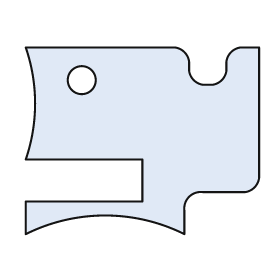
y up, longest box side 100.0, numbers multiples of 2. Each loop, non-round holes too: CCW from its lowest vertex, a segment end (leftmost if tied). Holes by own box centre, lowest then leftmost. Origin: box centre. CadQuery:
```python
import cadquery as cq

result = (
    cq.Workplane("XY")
    .moveTo(-50.0, -40.0)
    .threePointArc((-16.0, -32.0), (18.0, -40.0))
    .lineTo(18.0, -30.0)
    .threePointArc((20.0, -24.0), (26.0, -22.0))
    .lineTo(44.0, -22.0)
    .threePointArc((48.0, -20.0), (50.0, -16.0))
    .lineTo(50.0, 40.0)
    .lineTo(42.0, 40.0)
    .threePointArc((38.0, 38.0), (36.0, 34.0))
    .lineTo(36.0, 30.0)
    .threePointArc((34.0, 26.0), (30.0, 24.0))
    .lineTo(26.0, 24.0)
    .threePointArc((22.0, 26.0), (20.0, 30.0))
    .lineTo(20.0, 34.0)
    .threePointArc((18.0, 38.0), (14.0, 40.0))
    .lineTo(-50.0, 40.0)
    .threePointArc((-46.0, 16.0), (-50.0, -8.0))
    .lineTo(0.0, -8.0)
    .lineTo(0.0, -26.0)
    .lineTo(-50.0, -26.0)
    .close()
    .moveTo(-26.0, 26.0)
    .circle(6.0)
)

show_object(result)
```